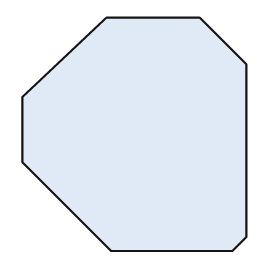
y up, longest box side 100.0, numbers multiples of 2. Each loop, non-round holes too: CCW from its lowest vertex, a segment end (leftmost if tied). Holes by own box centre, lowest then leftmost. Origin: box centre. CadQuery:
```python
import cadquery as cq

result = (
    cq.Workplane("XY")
    .moveTo(-10.0, -50.0)
    .lineTo(42.0, -50.0)
    .lineTo(48.0, -44.0)
    .lineTo(48.0, 30.0)
    .lineTo(28.0, 50.0)
    .lineTo(-12.0, 50.0)
    .lineTo(-48.0, 16.0)
    .lineTo(-48.0, -12.0)
    .close()
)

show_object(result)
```